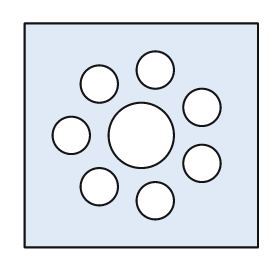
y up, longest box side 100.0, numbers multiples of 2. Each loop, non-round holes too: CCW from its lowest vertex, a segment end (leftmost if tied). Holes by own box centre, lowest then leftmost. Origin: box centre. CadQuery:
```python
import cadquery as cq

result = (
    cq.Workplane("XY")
    .moveTo(-50.0, -48.0)
    .lineTo(50.0, -48.0)
    .lineTo(50.0, 48.0)
    .lineTo(-50.0, 48.0)
    .close()
    .moveTo(6.0, -28.0)
    .circle(8.0)
    .moveTo(-18.0, -22.0)
    .circle(8.0)
    .moveTo(26.0, -12.0)
    .circle(8.0)
    .moveTo(-30.0, 0.0)
    .circle(8.0)
    .moveTo(0.0, 0.0)
    .circle(14.0)
    .moveTo(26.0, 12.0)
    .circle(8.0)
    .moveTo(-18.0, 22.0)
    .circle(8.0)
    .moveTo(6.0, 28.0)
    .circle(8.0)
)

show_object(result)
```